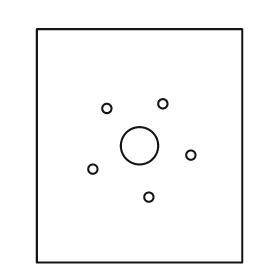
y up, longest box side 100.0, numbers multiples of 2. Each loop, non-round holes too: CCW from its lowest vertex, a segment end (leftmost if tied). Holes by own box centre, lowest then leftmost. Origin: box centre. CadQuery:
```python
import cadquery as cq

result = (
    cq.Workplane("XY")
    .moveTo(-44.0, -50.0)
    .lineTo(44.0, -50.0)
    .lineTo(44.0, 50.0)
    .lineTo(-44.0, 50.0)
    .close()
    .moveTo(4.0, -22.0)
    .circle(2.0)
    .moveTo(-20.0, -10.0)
    .circle(2.0)
    .moveTo(22.0, -4.0)
    .circle(2.0)
    .moveTo(0.0, 0.0)
    .circle(8.0)
    .moveTo(-14.0, 16.0)
    .circle(2.0)
    .moveTo(10.0, 18.0)
    .circle(2.0)
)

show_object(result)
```